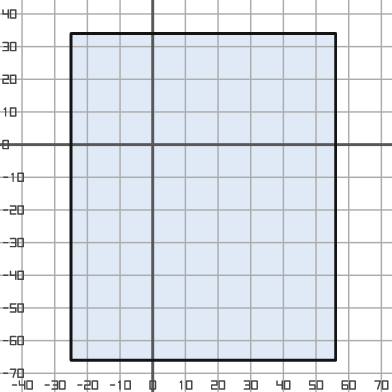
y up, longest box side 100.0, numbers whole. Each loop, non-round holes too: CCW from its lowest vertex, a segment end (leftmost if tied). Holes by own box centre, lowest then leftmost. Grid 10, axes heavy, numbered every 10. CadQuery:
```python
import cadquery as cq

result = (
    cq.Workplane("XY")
    .moveTo(-25.0, -66.0)
    .lineTo(56.0, -66.0)
    .lineTo(56.0, 34.0)
    .lineTo(-25.0, 34.0)
    .close()
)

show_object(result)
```